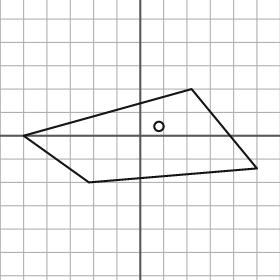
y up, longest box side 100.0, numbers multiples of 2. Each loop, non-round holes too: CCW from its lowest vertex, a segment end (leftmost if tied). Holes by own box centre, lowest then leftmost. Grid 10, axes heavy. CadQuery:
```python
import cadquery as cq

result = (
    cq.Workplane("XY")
    .moveTo(-22.0, -20.0)
    .lineTo(50.0, -14.0)
    .lineTo(22.0, 20.0)
    .lineTo(-50.0, 0.0)
    .close()
    .moveTo(8.0, 4.0)
    .circle(2.0)
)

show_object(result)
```